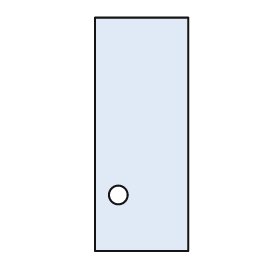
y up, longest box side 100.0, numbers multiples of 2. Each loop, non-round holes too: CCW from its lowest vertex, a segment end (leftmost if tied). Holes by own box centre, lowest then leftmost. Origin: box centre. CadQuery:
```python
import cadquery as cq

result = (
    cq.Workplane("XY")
    .moveTo(-20.0, -50.0)
    .lineTo(20.0, -50.0)
    .lineTo(20.0, 50.0)
    .lineTo(-20.0, 50.0)
    .close()
    .moveTo(-10.0, -26.0)
    .circle(4.0)
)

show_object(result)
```